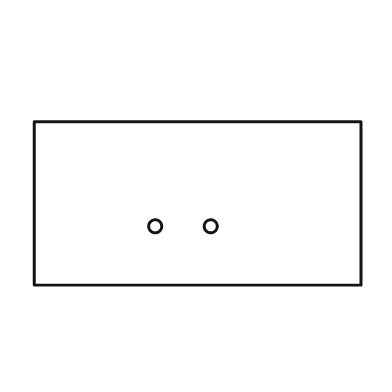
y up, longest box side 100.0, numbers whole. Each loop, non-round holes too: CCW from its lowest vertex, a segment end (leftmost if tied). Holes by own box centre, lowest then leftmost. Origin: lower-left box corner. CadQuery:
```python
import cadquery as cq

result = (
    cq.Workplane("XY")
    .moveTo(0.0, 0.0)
    .lineTo(100.0, 0.0)
    .lineTo(100.0, 50.0)
    .lineTo(0.0, 50.0)
    .close()
    .moveTo(37.0, 18.0)
    .circle(2.0)
    .moveTo(54.0, 18.0)
    .circle(2.0)
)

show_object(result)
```